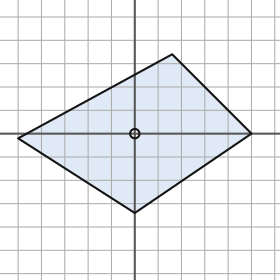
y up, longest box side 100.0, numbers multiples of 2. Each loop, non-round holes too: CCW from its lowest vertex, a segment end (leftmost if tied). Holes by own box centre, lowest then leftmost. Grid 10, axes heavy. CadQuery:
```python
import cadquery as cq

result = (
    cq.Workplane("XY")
    .moveTo(0.0, -34.0)
    .lineTo(50.0, 0.0)
    .lineTo(16.0, 34.0)
    .lineTo(-50.0, -2.0)
    .close()
    .moveTo(0.0, 0.0)
    .circle(2.0)
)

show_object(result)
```